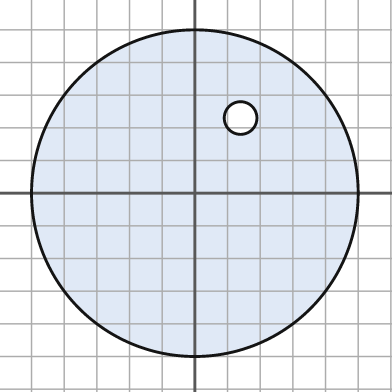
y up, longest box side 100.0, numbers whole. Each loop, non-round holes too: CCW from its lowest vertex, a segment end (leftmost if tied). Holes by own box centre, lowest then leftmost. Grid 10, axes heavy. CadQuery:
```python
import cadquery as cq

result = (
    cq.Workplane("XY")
    .moveTo(0.0, 0.0)
    .circle(50.0)
    .moveTo(14.0, 23.0)
    .circle(5.0)
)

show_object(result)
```